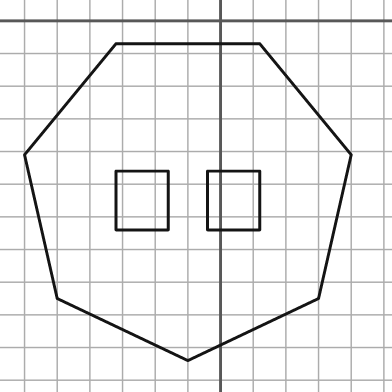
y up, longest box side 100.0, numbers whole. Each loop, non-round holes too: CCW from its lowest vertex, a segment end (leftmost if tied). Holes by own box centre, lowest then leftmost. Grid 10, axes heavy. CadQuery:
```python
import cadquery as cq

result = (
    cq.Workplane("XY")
    .moveTo(-10.0, -104.0)
    .lineTo(30.0, -85.0)
    .lineTo(40.0, -41.0)
    .lineTo(12.0, -7.0)
    .lineTo(-32.0, -7.0)
    .lineTo(-60.0, -41.0)
    .lineTo(-50.0, -85.0)
    .close()
    .moveTo(-32.0, -64.0)
    .lineTo(-16.0, -64.0)
    .lineTo(-16.0, -46.0)
    .lineTo(-32.0, -46.0)
    .close()
    .moveTo(-4.0, -64.0)
    .lineTo(12.0, -64.0)
    .lineTo(12.0, -46.0)
    .lineTo(-4.0, -46.0)
    .close()
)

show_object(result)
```